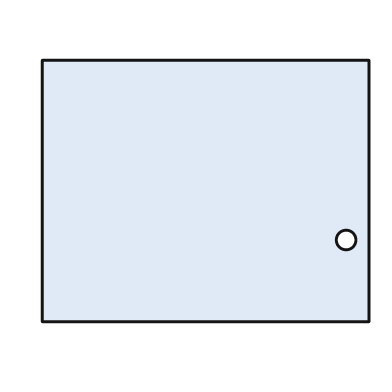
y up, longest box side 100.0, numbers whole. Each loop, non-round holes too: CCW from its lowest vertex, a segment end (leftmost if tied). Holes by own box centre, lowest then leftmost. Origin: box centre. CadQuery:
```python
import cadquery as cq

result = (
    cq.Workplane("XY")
    .moveTo(-50.0, -40.0)
    .lineTo(50.0, -40.0)
    .lineTo(50.0, 40.0)
    .lineTo(-50.0, 40.0)
    .close()
    .moveTo(43.0, -15.0)
    .circle(3.0)
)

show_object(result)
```